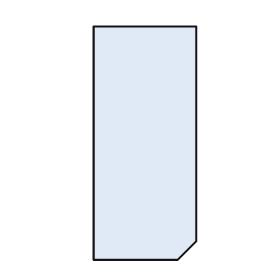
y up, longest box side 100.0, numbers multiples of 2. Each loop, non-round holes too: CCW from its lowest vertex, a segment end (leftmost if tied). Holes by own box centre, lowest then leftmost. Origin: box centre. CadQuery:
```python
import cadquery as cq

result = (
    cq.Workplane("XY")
    .moveTo(-22.0, -50.0)
    .lineTo(14.0, -50.0)
    .lineTo(22.0, -42.0)
    .lineTo(22.0, 50.0)
    .lineTo(-22.0, 50.0)
    .close()
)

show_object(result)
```